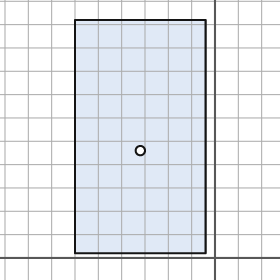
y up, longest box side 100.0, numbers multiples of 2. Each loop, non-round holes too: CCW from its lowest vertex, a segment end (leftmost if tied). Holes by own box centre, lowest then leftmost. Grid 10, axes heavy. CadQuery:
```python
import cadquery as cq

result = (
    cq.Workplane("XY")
    .moveTo(-60.0, 2.0)
    .lineTo(-4.0, 2.0)
    .lineTo(-4.0, 102.0)
    .lineTo(-60.0, 102.0)
    .close()
    .moveTo(-32.0, 46.0)
    .circle(2.0)
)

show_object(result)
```